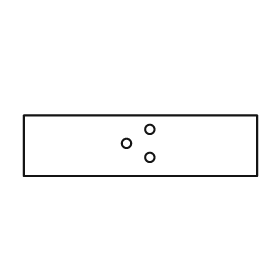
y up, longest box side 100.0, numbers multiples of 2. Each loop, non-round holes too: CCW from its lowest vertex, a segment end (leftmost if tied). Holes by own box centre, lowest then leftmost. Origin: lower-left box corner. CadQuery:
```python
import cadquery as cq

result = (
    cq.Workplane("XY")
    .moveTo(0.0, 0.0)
    .lineTo(100.0, 0.0)
    .lineTo(100.0, 26.0)
    .lineTo(0.0, 26.0)
    .close()
    .moveTo(54.0, 8.0)
    .circle(2.0)
    .moveTo(44.0, 14.0)
    .circle(2.0)
    .moveTo(54.0, 20.0)
    .circle(2.0)
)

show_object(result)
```